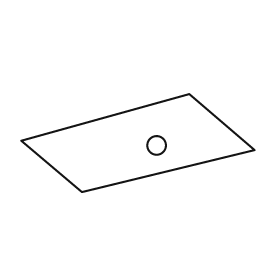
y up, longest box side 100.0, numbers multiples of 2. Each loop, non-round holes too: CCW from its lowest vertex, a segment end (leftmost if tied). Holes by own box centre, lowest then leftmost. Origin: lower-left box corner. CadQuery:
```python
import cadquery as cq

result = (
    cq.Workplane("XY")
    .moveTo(26.0, 0.0)
    .lineTo(100.0, 18.0)
    .lineTo(72.0, 42.0)
    .lineTo(0.0, 22.0)
    .close()
    .moveTo(58.0, 20.0)
    .circle(4.0)
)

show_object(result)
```